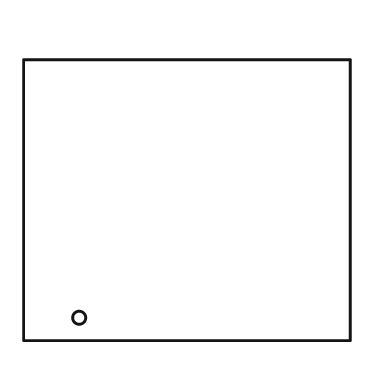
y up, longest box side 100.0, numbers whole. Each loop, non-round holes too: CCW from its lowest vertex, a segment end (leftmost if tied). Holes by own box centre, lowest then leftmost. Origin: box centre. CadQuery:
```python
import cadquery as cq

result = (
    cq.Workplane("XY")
    .moveTo(-50.0, -43.0)
    .lineTo(50.0, -43.0)
    .lineTo(50.0, 43.0)
    .lineTo(-50.0, 43.0)
    .close()
    .moveTo(-33.0, -36.0)
    .circle(2.0)
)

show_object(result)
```